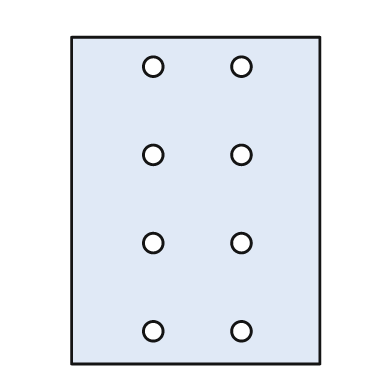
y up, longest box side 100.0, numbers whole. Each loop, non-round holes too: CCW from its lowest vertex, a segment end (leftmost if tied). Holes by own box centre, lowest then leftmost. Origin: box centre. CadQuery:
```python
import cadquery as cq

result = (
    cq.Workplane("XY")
    .moveTo(-38.0, -50.0)
    .lineTo(38.0, -50.0)
    .lineTo(38.0, 50.0)
    .lineTo(-38.0, 50.0)
    .close()
    .moveTo(-13.0, -40.0)
    .circle(3.0)
    .moveTo(14.0, -40.0)
    .circle(3.0)
    .moveTo(-13.0, -13.0)
    .circle(3.0)
    .moveTo(14.0, -13.0)
    .circle(3.0)
    .moveTo(-13.0, 14.0)
    .circle(3.0)
    .moveTo(14.0, 14.0)
    .circle(3.0)
    .moveTo(-13.0, 41.0)
    .circle(3.0)
    .moveTo(14.0, 41.0)
    .circle(3.0)
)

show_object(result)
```